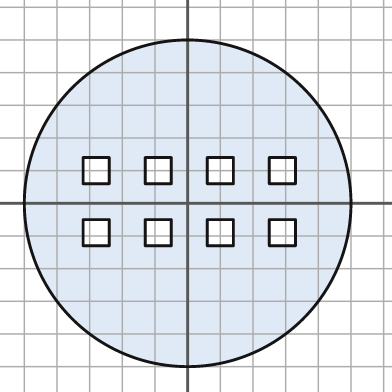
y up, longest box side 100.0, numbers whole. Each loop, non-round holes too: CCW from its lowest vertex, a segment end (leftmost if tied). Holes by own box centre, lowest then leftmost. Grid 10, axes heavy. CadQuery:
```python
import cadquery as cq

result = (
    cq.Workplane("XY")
    .moveTo(0.0, 0.0)
    .circle(50.0)
    .moveTo(-32.0, -13.0)
    .lineTo(-24.0, -13.0)
    .lineTo(-24.0, -5.0)
    .lineTo(-32.0, -5.0)
    .close()
    .moveTo(-13.0, -13.0)
    .lineTo(-5.0, -13.0)
    .lineTo(-5.0, -5.0)
    .lineTo(-13.0, -5.0)
    .close()
    .moveTo(6.0, -13.0)
    .lineTo(14.0, -13.0)
    .lineTo(14.0, -5.0)
    .lineTo(6.0, -5.0)
    .close()
    .moveTo(25.0, -13.0)
    .lineTo(33.0, -13.0)
    .lineTo(33.0, -5.0)
    .lineTo(25.0, -5.0)
    .close()
    .moveTo(-32.0, 6.0)
    .lineTo(-24.0, 6.0)
    .lineTo(-24.0, 14.0)
    .lineTo(-32.0, 14.0)
    .close()
    .moveTo(-13.0, 6.0)
    .lineTo(-5.0, 6.0)
    .lineTo(-5.0, 14.0)
    .lineTo(-13.0, 14.0)
    .close()
    .moveTo(6.0, 6.0)
    .lineTo(14.0, 6.0)
    .lineTo(14.0, 14.0)
    .lineTo(6.0, 14.0)
    .close()
    .moveTo(25.0, 6.0)
    .lineTo(33.0, 6.0)
    .lineTo(33.0, 14.0)
    .lineTo(25.0, 14.0)
    .close()
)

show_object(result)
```